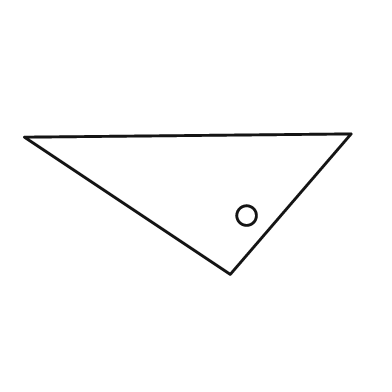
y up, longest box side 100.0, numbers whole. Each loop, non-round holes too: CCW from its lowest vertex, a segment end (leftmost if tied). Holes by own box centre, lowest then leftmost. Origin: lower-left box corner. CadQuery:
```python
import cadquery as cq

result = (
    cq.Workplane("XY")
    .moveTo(63.0, 0.0)
    .lineTo(100.0, 43.0)
    .lineTo(0.0, 42.0)
    .close()
    .moveTo(68.0, 18.0)
    .circle(3.0)
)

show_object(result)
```